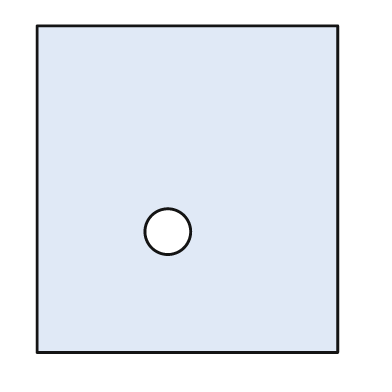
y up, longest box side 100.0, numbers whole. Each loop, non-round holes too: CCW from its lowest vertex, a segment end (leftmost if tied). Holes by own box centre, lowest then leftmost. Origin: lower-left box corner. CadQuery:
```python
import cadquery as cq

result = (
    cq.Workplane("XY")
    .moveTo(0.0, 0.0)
    .lineTo(92.0, 0.0)
    .lineTo(92.0, 100.0)
    .lineTo(0.0, 100.0)
    .close()
    .moveTo(40.0, 37.0)
    .circle(7.0)
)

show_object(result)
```